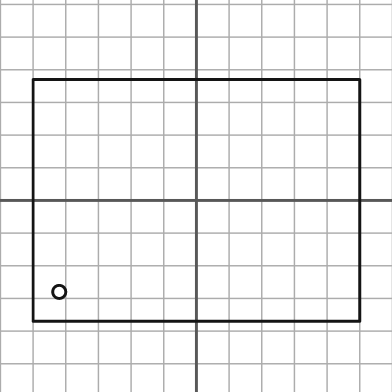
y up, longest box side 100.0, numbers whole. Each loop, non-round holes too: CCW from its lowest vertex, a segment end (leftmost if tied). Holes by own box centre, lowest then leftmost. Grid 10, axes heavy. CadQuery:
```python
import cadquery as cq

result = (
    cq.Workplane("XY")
    .moveTo(-50.0, -37.0)
    .lineTo(50.0, -37.0)
    .lineTo(50.0, 37.0)
    .lineTo(-50.0, 37.0)
    .close()
    .moveTo(-42.0, -28.0)
    .circle(2.0)
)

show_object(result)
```